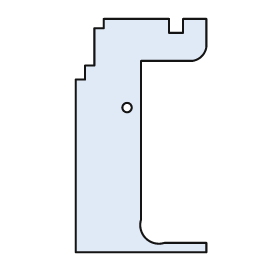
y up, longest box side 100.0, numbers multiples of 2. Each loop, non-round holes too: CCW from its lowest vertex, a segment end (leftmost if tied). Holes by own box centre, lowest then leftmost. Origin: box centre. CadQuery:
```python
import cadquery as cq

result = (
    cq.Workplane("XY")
    .moveTo(-28.0, -50.0)
    .lineTo(28.0, -50.0)
    .lineTo(28.0, -46.0)
    .lineTo(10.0, -46.0)
    .threePointArc((2.0, -44.0), (0.0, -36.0))
    .lineTo(0.0, 32.0)
    .lineTo(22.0, 32.0)
    .threePointArc((26.0, 34.0), (28.0, 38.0))
    .lineTo(28.0, 50.0)
    .lineTo(18.0, 50.0)
    .lineTo(18.0, 44.0)
    .lineTo(12.0, 44.0)
    .lineTo(12.0, 50.0)
    .lineTo(-16.0, 50.0)
    .lineTo(-16.0, 46.0)
    .lineTo(-20.0, 46.0)
    .lineTo(-20.0, 30.0)
    .lineTo(-24.0, 30.0)
    .lineTo(-24.0, 24.0)
    .lineTo(-28.0, 24.0)
    .close()
    .moveTo(-6.0, 12.0)
    .circle(2.0)
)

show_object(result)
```